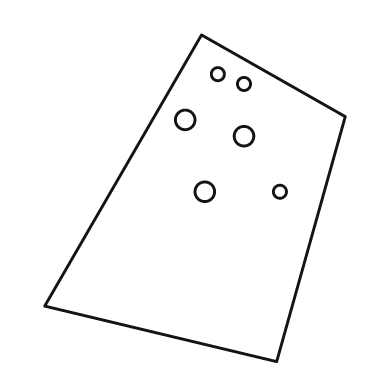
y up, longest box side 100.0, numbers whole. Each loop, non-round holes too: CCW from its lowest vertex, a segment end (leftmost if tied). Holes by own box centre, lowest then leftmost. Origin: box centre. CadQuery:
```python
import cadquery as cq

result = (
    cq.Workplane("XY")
    .moveTo(25.0, -50.0)
    .lineTo(46.0, 25.0)
    .lineTo(2.0, 50.0)
    .lineTo(-46.0, -33.0)
    .close()
    .moveTo(3.0, 2.0)
    .circle(3.0)
    .moveTo(26.0, 2.0)
    .circle(2.0)
    .moveTo(15.0, 19.0)
    .circle(3.0)
    .moveTo(-3.0, 24.0)
    .circle(3.0)
    .moveTo(15.0, 35.0)
    .circle(2.0)
    .moveTo(7.0, 38.0)
    .circle(2.0)
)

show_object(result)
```